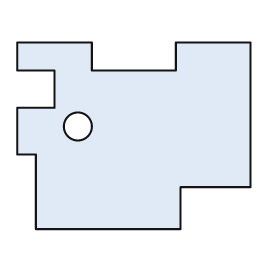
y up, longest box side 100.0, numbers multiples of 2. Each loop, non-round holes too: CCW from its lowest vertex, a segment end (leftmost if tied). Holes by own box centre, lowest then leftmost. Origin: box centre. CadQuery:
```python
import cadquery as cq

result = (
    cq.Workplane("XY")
    .moveTo(-42.0, -40.0)
    .lineTo(20.0, -40.0)
    .lineTo(20.0, -22.0)
    .lineTo(50.0, -22.0)
    .lineTo(50.0, 40.0)
    .lineTo(18.0, 40.0)
    .lineTo(18.0, 28.0)
    .lineTo(-18.0, 28.0)
    .lineTo(-18.0, 40.0)
    .lineTo(-50.0, 40.0)
    .lineTo(-50.0, 28.0)
    .lineTo(-34.0, 28.0)
    .lineTo(-34.0, 12.0)
    .lineTo(-50.0, 12.0)
    .lineTo(-50.0, -8.0)
    .lineTo(-42.0, -8.0)
    .close()
    .moveTo(-24.0, 4.0)
    .circle(6.0)
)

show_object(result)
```